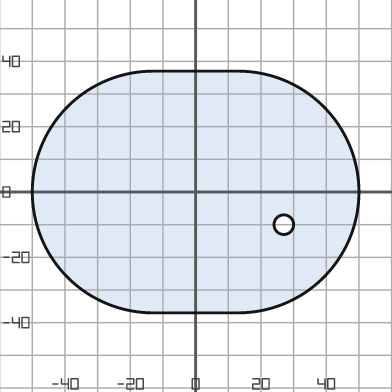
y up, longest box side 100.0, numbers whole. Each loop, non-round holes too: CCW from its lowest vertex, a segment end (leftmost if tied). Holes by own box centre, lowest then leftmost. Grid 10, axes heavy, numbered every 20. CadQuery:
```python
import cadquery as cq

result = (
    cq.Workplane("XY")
    .moveTo(-13.0, -37.0)
    .lineTo(13.0, -37.0)
    .threePointArc((50.0, 0.0), (13.0, 37.0))
    .lineTo(-13.0, 37.0)
    .threePointArc((-50.0, 0.0), (-13.0, -37.0))
    .close()
    .moveTo(27.0, -10.0)
    .circle(3.0)
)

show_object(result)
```